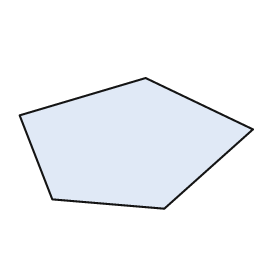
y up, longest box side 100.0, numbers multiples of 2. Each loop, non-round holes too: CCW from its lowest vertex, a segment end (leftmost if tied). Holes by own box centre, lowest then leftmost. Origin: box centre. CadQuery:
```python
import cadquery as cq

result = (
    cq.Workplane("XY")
    .moveTo(12.0, -28.0)
    .lineTo(50.0, 6.0)
    .lineTo(4.0, 28.0)
    .lineTo(-50.0, 12.0)
    .lineTo(-36.0, -24.0)
    .close()
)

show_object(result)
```